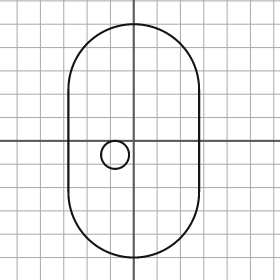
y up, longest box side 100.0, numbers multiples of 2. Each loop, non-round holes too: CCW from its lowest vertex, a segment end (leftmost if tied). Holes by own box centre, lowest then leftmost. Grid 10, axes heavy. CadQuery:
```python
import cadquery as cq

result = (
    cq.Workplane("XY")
    .moveTo(-28.0, -22.0)
    .threePointArc((0.0, -50.0), (28.0, -22.0))
    .lineTo(28.0, 22.0)
    .threePointArc((0.0, 50.0), (-28.0, 22.0))
    .close()
    .moveTo(-8.0, -6.0)
    .circle(6.0)
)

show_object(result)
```